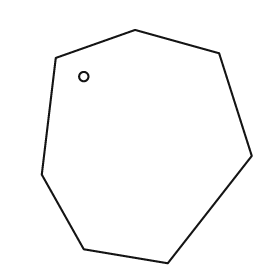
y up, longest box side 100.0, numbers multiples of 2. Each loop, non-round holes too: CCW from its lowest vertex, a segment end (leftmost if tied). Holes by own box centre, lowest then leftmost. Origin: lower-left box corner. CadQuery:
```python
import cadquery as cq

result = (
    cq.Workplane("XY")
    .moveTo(54.0, 0.0)
    .lineTo(90.0, 46.0)
    .lineTo(76.0, 90.0)
    .lineTo(40.0, 100.0)
    .lineTo(6.0, 88.0)
    .lineTo(0.0, 38.0)
    .lineTo(18.0, 6.0)
    .close()
    .moveTo(18.0, 80.0)
    .circle(2.0)
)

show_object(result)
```